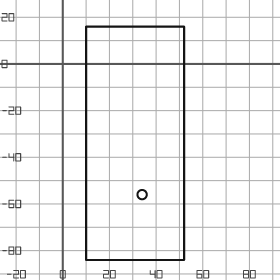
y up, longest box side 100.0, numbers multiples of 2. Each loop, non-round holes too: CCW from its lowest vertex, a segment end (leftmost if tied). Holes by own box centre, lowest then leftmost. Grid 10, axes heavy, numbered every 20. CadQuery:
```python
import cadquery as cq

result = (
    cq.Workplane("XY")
    .moveTo(10.0, -84.0)
    .lineTo(52.0, -84.0)
    .lineTo(52.0, 16.0)
    .lineTo(10.0, 16.0)
    .close()
    .moveTo(34.0, -56.0)
    .circle(2.0)
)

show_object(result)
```